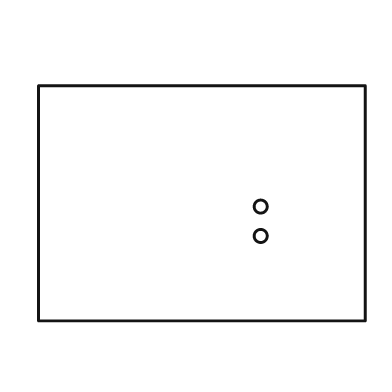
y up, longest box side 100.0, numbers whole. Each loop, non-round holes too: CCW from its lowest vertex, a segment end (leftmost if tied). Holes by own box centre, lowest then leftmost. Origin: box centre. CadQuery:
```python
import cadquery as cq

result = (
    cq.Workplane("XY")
    .moveTo(-50.0, -36.0)
    .lineTo(50.0, -36.0)
    .lineTo(50.0, 36.0)
    .lineTo(-50.0, 36.0)
    .close()
    .moveTo(18.0, -10.0)
    .circle(2.0)
    .moveTo(18.0, -1.0)
    .circle(2.0)
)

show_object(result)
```